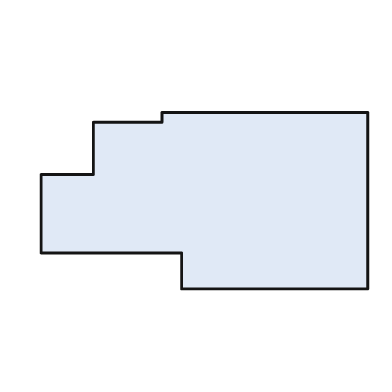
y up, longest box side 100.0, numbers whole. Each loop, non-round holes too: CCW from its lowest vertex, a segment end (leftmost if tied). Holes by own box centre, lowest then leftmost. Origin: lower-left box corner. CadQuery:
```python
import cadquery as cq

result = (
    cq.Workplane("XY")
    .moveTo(43.0, 0.0)
    .lineTo(100.0, 0.0)
    .lineTo(100.0, 54.0)
    .lineTo(37.0, 54.0)
    .lineTo(37.0, 51.0)
    .lineTo(16.0, 51.0)
    .lineTo(16.0, 35.0)
    .lineTo(0.0, 35.0)
    .lineTo(0.0, 11.0)
    .lineTo(43.0, 11.0)
    .close()
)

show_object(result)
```